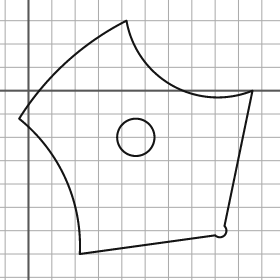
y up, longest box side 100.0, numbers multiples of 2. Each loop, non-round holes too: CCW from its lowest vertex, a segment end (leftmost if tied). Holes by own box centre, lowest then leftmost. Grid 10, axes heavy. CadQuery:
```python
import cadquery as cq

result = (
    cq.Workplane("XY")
    .moveTo(22.0, -70.0)
    .lineTo(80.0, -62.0)
    .threePointArc((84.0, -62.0), (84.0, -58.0))
    .lineTo(96.0, 0.0)
    .threePointArc((62.0, 2.0), (42.0, 30.0))
    .threePointArc((16.0, 12.0), (-4.0, -12.0))
    .threePointArc((16.0, -38.0), (22.0, -70.0))
    .close()
    .moveTo(46.0, -20.0)
    .circle(8.0)
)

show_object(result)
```